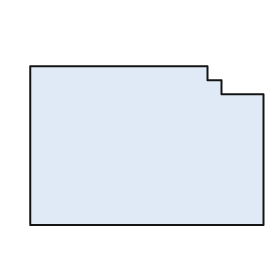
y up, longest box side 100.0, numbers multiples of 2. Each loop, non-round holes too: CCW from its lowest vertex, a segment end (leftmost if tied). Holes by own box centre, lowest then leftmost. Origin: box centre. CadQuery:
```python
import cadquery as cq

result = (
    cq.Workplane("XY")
    .moveTo(-50.0, -34.0)
    .lineTo(50.0, -34.0)
    .lineTo(50.0, 22.0)
    .lineTo(32.0, 22.0)
    .lineTo(32.0, 28.0)
    .lineTo(26.0, 28.0)
    .lineTo(26.0, 34.0)
    .lineTo(-50.0, 34.0)
    .close()
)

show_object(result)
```